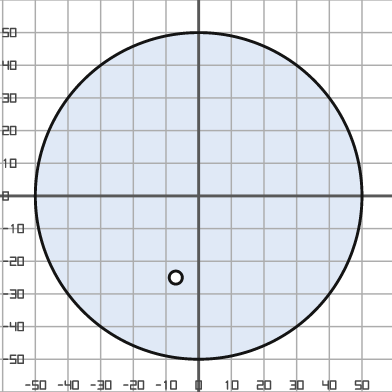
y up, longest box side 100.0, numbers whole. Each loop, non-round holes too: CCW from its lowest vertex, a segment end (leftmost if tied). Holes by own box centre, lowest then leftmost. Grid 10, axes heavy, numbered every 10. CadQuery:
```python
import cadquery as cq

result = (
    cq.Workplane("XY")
    .moveTo(0.0, 0.0)
    .circle(50.0)
    .moveTo(-7.0, -25.0)
    .circle(2.0)
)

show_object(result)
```